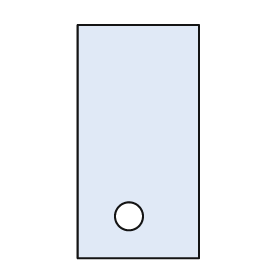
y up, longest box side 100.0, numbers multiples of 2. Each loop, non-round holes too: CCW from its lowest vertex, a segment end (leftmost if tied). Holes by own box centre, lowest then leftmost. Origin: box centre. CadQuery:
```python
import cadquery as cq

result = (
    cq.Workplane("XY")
    .moveTo(-26.0, -50.0)
    .lineTo(26.0, -50.0)
    .lineTo(26.0, 50.0)
    .lineTo(-26.0, 50.0)
    .close()
    .moveTo(-4.0, -32.0)
    .circle(6.0)
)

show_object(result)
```